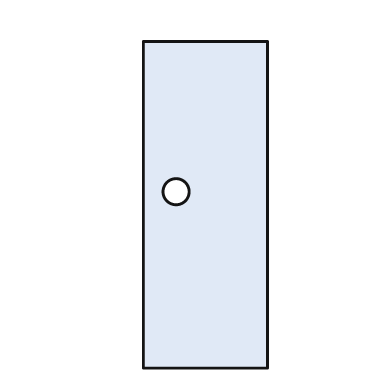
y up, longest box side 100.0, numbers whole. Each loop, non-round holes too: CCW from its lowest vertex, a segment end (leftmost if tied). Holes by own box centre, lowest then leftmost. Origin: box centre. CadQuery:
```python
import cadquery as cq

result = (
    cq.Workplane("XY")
    .moveTo(-19.0, -50.0)
    .lineTo(19.0, -50.0)
    .lineTo(19.0, 50.0)
    .lineTo(-19.0, 50.0)
    .close()
    .moveTo(-9.0, 4.0)
    .circle(4.0)
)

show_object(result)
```